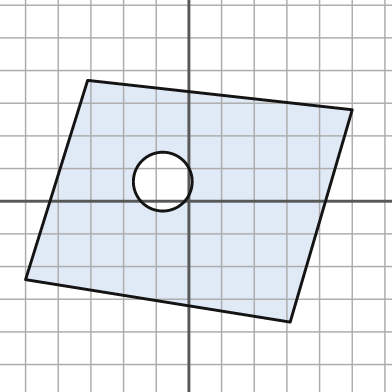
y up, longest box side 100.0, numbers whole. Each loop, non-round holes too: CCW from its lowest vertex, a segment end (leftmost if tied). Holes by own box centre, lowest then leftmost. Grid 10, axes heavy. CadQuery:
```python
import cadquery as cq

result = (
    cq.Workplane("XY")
    .moveTo(31.0, -37.0)
    .lineTo(50.0, 28.0)
    .lineTo(-31.0, 37.0)
    .lineTo(-50.0, -24.0)
    .close()
    .moveTo(-8.0, 6.0)
    .circle(9.0)
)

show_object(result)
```